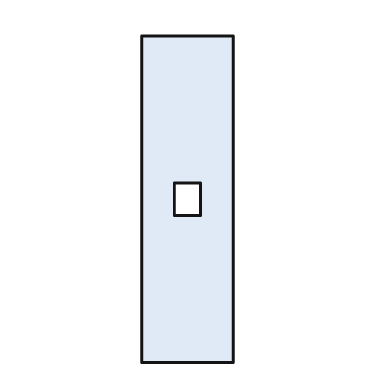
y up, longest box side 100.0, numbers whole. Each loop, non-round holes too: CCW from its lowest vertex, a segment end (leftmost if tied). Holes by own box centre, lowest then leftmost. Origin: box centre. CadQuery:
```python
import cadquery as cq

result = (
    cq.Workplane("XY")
    .moveTo(-14.0, -50.0)
    .lineTo(14.0, -50.0)
    .lineTo(14.0, 50.0)
    .lineTo(-14.0, 50.0)
    .close()
    .moveTo(-4.0, -5.0)
    .lineTo(4.0, -5.0)
    .lineTo(4.0, 5.0)
    .lineTo(-4.0, 5.0)
    .close()
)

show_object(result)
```